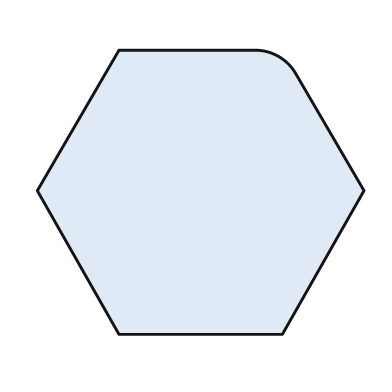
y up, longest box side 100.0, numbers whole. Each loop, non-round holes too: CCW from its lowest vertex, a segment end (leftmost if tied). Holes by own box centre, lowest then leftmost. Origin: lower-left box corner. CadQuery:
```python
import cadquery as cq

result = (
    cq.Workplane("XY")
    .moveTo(25.0, 0.0)
    .lineTo(75.0, 0.0)
    .lineTo(100.0, 44.0)
    .lineTo(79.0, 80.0)
    .threePointArc((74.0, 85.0), (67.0, 87.0))
    .lineTo(25.0, 87.0)
    .lineTo(0.0, 44.0)
    .close()
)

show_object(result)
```